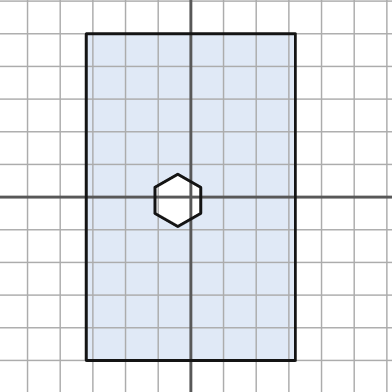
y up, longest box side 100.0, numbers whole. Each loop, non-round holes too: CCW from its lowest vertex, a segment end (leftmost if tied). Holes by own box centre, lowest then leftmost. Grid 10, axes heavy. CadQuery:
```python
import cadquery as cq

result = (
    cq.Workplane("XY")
    .moveTo(-32.0, -50.0)
    .lineTo(32.0, -50.0)
    .lineTo(32.0, 50.0)
    .lineTo(-32.0, 50.0)
    .close()
    .moveTo(-4.0, -9.0)
    .lineTo(3.0, -5.0)
    .lineTo(3.0, 3.0)
    .lineTo(-4.0, 7.0)
    .lineTo(-11.0, 3.0)
    .lineTo(-11.0, -5.0)
    .close()
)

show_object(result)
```